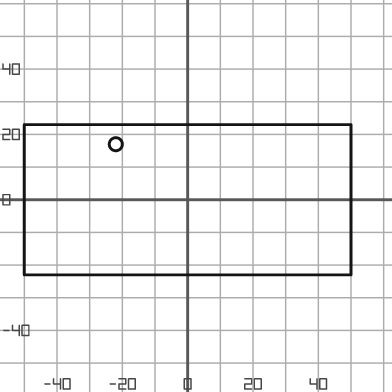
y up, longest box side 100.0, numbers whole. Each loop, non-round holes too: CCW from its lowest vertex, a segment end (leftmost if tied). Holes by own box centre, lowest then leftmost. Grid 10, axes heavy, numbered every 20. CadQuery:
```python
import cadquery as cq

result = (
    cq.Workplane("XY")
    .moveTo(-50.0, -23.0)
    .lineTo(50.0, -23.0)
    .lineTo(50.0, 23.0)
    .lineTo(-50.0, 23.0)
    .close()
    .moveTo(-22.0, 17.0)
    .circle(2.0)
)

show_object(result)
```